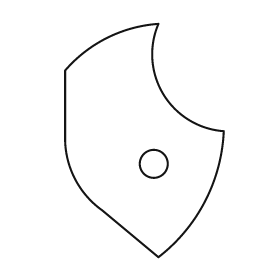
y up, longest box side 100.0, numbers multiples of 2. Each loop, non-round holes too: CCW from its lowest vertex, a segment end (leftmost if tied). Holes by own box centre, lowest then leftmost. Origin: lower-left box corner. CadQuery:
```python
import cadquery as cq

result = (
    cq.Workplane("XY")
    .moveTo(40.0, 0.0)
    .threePointArc((60.0, 24.0), (68.0, 54.0))
    .threePointArc((42.0, 70.0), (40.0, 100.0))
    .threePointArc((18.0, 94.0), (0.0, 80.0))
    .lineTo(0.0, 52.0)
    .threePointArc((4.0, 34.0), (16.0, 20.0))
    .close()
    .moveTo(38.0, 40.0)
    .circle(6.0)
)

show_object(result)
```